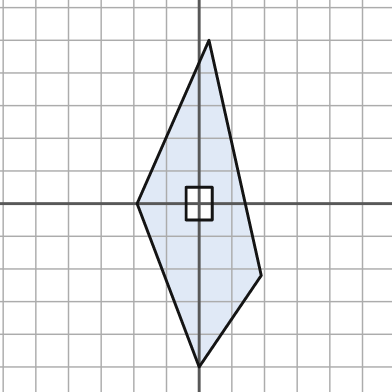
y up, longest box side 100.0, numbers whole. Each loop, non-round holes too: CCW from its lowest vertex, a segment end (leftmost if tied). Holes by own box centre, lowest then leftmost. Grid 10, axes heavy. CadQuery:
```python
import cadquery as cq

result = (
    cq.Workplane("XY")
    .moveTo(0.0, -50.0)
    .lineTo(19.0, -22.0)
    .lineTo(3.0, 50.0)
    .lineTo(-19.0, 0.0)
    .close()
    .moveTo(-4.0, -5.0)
    .lineTo(4.0, -5.0)
    .lineTo(4.0, 5.0)
    .lineTo(-4.0, 5.0)
    .close()
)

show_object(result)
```